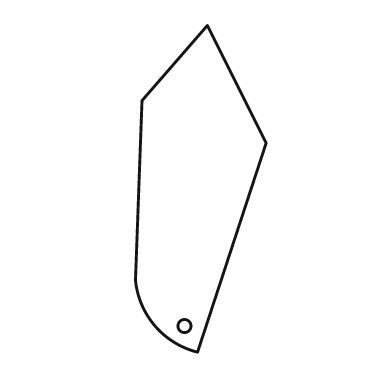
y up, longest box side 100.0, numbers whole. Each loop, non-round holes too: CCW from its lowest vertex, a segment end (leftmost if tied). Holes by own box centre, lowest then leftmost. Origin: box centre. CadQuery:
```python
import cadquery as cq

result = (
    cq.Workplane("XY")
    .moveTo(-1.0, -50.0)
    .lineTo(20.0, 14.0)
    .lineTo(2.0, 50.0)
    .lineTo(-18.0, 27.0)
    .lineTo(-20.0, -28.0)
    .threePointArc((-14.0, -42.0), (-1.0, -50.0))
    .close()
    .moveTo(-5.0, -42.0)
    .circle(2.0)
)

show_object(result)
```